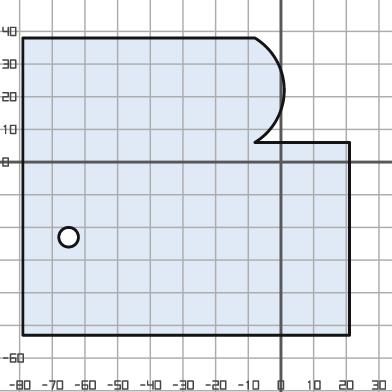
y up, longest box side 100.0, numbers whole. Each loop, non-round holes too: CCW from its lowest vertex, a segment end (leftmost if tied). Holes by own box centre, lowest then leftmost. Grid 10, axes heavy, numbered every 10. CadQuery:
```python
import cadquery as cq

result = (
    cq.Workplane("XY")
    .moveTo(-79.0, -53.0)
    .lineTo(21.0, -53.0)
    .lineTo(21.0, 6.0)
    .lineTo(-8.0, 6.0)
    .threePointArc((1.0, 22.0), (-8.0, 38.0))
    .lineTo(-79.0, 38.0)
    .close()
    .moveTo(-65.0, -23.0)
    .circle(3.0)
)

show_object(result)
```